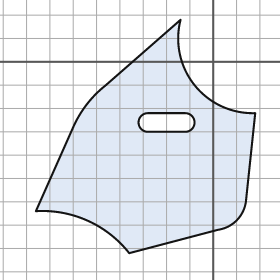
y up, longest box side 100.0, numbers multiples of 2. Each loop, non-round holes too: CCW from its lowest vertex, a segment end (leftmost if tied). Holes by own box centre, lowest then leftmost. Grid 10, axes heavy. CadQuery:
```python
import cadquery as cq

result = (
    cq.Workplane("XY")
    .moveTo(-36.0, -82.0)
    .lineTo(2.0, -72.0)
    .threePointArc((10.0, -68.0), (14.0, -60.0))
    .lineTo(18.0, -22.0)
    .threePointArc((-8.0, -10.0), (-14.0, 18.0))
    .lineTo(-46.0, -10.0)
    .threePointArc((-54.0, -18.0), (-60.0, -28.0))
    .lineTo(-76.0, -64.0)
    .threePointArc((-54.0, -68.0), (-36.0, -82.0))
    .close()
    .moveTo(-28.0, -30.0)
    .lineTo(-12.0, -30.0)
    .threePointArc((-8.0, -26.0), (-12.0, -22.0))
    .lineTo(-28.0, -22.0)
    .threePointArc((-32.0, -26.0), (-28.0, -30.0))
    .close()
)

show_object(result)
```